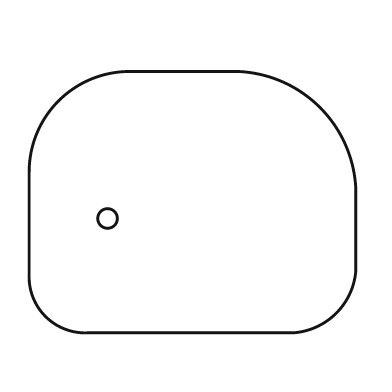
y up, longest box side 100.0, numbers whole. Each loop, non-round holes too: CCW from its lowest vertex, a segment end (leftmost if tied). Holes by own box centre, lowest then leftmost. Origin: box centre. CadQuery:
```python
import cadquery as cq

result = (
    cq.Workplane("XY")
    .moveTo(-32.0, -40.0)
    .lineTo(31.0, -40.0)
    .threePointArc((44.0, -34.0), (50.0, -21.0))
    .lineTo(50.0, 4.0)
    .threePointArc((39.0, 29.0), (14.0, 40.0))
    .lineTo(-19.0, 40.0)
    .threePointArc((-41.0, 31.0), (-50.0, 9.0))
    .lineTo(-50.0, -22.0)
    .threePointArc((-45.0, -35.0), (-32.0, -40.0))
    .close()
    .moveTo(-26.0, -5.0)
    .circle(3.0)
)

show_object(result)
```